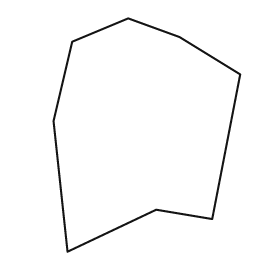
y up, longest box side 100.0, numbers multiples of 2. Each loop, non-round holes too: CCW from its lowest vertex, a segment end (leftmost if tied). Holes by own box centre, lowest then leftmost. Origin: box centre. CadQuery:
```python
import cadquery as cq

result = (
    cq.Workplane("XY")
    .moveTo(-34.0, -50.0)
    .lineTo(4.0, -32.0)
    .lineTo(28.0, -36.0)
    .lineTo(40.0, 26.0)
    .lineTo(14.0, 42.0)
    .lineTo(-8.0, 50.0)
    .lineTo(-32.0, 40.0)
    .lineTo(-40.0, 6.0)
    .close()
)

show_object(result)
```